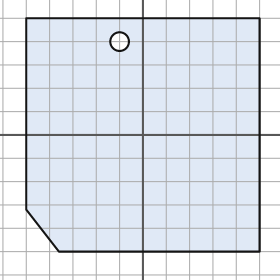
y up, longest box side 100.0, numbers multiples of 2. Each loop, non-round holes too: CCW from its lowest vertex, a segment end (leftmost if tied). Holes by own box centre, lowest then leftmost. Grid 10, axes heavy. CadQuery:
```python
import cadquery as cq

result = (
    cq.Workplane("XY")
    .moveTo(-36.0, -50.0)
    .lineTo(50.0, -50.0)
    .lineTo(50.0, 50.0)
    .lineTo(-50.0, 50.0)
    .lineTo(-50.0, -32.0)
    .close()
    .moveTo(-10.0, 40.0)
    .circle(4.0)
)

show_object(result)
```